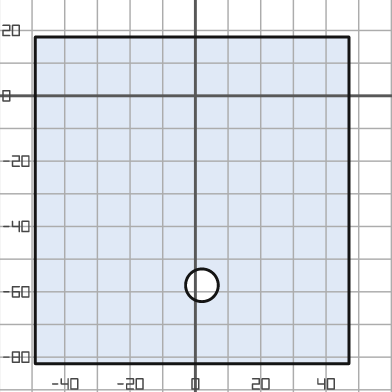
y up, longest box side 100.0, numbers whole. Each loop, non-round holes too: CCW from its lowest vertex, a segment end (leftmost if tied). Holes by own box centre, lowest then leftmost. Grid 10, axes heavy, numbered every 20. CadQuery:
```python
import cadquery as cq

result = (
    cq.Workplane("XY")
    .moveTo(-49.0, -82.0)
    .lineTo(47.0, -82.0)
    .lineTo(47.0, 18.0)
    .lineTo(-49.0, 18.0)
    .close()
    .moveTo(2.0, -58.0)
    .circle(5.0)
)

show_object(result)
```